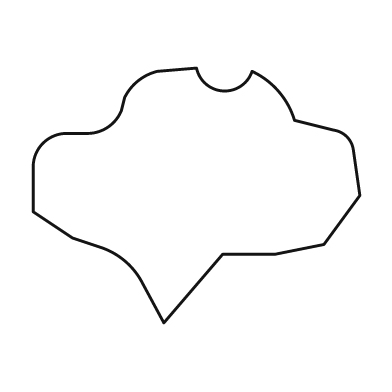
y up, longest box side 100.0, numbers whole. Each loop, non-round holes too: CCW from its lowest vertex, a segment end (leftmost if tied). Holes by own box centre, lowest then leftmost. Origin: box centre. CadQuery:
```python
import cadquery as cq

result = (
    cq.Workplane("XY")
    .moveTo(-10.0, -39.0)
    .lineTo(8.0, -18.0)
    .lineTo(24.0, -18.0)
    .lineTo(39.0, -15.0)
    .lineTo(50.0, 0.0)
    .lineTo(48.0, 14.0)
    .threePointArc((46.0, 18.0), (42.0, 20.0))
    .lineTo(30.0, 23.0)
    .threePointArc((25.0, 32.0), (17.0, 38.0))
    .threePointArc((8.0, 32.0), (0.0, 39.0))
    .lineTo(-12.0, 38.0)
    .threePointArc((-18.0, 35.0), (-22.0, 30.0))
    .lineTo(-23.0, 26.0)
    .threePointArc((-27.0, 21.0), (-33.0, 19.0))
    .lineTo(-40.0, 19.0)
    .threePointArc((-47.0, 16.0), (-50.0, 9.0))
    .lineTo(-50.0, -5.0)
    .lineTo(-38.0, -13.0)
    .lineTo(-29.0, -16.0)
    .threePointArc((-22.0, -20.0), (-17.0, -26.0))
    .close()
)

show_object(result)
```